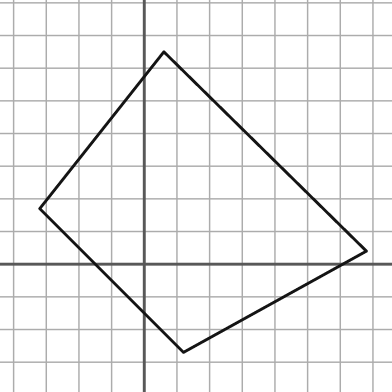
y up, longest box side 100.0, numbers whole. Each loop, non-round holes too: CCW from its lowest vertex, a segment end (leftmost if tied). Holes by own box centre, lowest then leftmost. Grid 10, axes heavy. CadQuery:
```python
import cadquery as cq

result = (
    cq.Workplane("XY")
    .moveTo(12.0, -27.0)
    .lineTo(68.0, 4.0)
    .lineTo(6.0, 65.0)
    .lineTo(-32.0, 17.0)
    .close()
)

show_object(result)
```